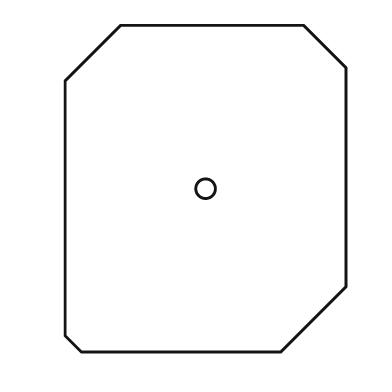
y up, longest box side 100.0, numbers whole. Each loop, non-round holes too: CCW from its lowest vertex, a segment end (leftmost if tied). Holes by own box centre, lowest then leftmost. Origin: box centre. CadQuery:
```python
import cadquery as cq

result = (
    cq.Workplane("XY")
    .moveTo(-38.0, -50.0)
    .lineTo(23.0, -50.0)
    .lineTo(43.0, -30.0)
    .lineTo(43.0, 37.0)
    .lineTo(30.0, 50.0)
    .lineTo(-26.0, 50.0)
    .lineTo(-43.0, 33.0)
    .lineTo(-43.0, -45.0)
    .close()
    .moveTo(0.0, 0.0)
    .circle(3.0)
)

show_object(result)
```